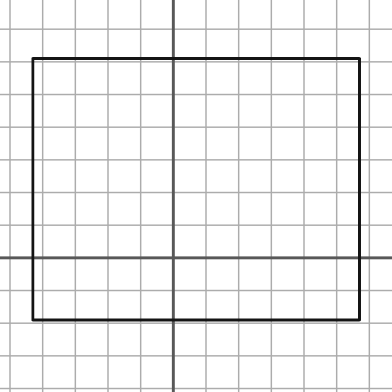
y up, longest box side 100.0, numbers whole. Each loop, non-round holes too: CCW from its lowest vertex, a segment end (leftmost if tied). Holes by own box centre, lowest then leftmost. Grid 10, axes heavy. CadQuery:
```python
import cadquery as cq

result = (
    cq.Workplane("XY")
    .moveTo(-43.0, -19.0)
    .lineTo(57.0, -19.0)
    .lineTo(57.0, 61.0)
    .lineTo(-43.0, 61.0)
    .close()
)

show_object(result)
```